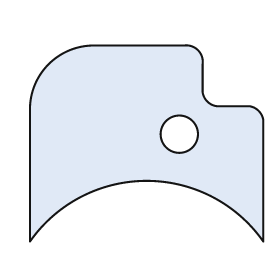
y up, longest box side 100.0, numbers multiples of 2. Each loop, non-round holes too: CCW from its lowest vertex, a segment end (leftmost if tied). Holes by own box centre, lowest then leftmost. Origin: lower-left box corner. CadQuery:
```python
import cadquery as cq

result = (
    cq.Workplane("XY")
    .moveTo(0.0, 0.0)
    .threePointArc((50.0, 26.0), (100.0, 0.0))
    .lineTo(100.0, 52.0)
    .threePointArc((98.0, 56.0), (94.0, 58.0))
    .lineTo(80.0, 58.0)
    .threePointArc((76.0, 60.0), (74.0, 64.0))
    .lineTo(74.0, 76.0)
    .threePointArc((72.0, 82.0), (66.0, 84.0))
    .lineTo(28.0, 84.0)
    .threePointArc((8.0, 76.0), (0.0, 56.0))
    .close()
    .moveTo(64.0, 46.0)
    .circle(8.0)
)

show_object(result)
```